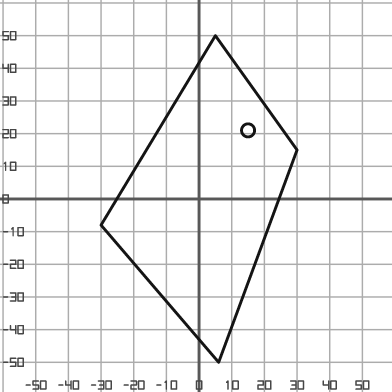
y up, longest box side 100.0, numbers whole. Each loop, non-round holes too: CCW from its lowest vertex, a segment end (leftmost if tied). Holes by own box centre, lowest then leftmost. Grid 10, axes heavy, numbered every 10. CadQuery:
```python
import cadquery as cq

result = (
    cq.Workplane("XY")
    .moveTo(6.0, -50.0)
    .lineTo(30.0, 15.0)
    .lineTo(5.0, 50.0)
    .lineTo(-30.0, -8.0)
    .close()
    .moveTo(15.0, 21.0)
    .circle(2.0)
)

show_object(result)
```